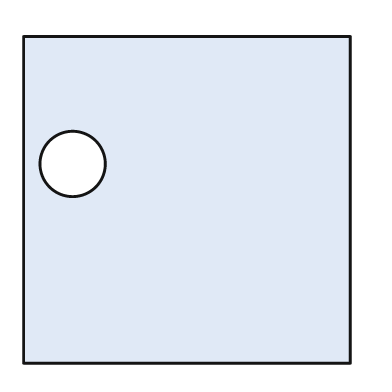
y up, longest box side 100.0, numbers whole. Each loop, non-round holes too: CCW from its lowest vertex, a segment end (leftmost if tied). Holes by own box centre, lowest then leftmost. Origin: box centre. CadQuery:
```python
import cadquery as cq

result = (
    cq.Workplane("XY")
    .moveTo(-50.0, -50.0)
    .lineTo(50.0, -50.0)
    .lineTo(50.0, 50.0)
    .lineTo(-50.0, 50.0)
    .close()
    .moveTo(-35.0, 11.0)
    .circle(10.0)
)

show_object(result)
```